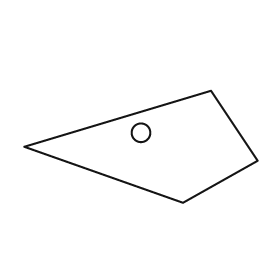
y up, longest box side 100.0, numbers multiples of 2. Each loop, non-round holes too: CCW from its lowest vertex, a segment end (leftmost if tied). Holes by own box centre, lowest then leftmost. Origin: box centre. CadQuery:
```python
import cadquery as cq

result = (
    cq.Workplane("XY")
    .moveTo(18.0, -24.0)
    .lineTo(50.0, -6.0)
    .lineTo(30.0, 24.0)
    .lineTo(-50.0, 0.0)
    .close()
    .moveTo(0.0, 6.0)
    .circle(4.0)
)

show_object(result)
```